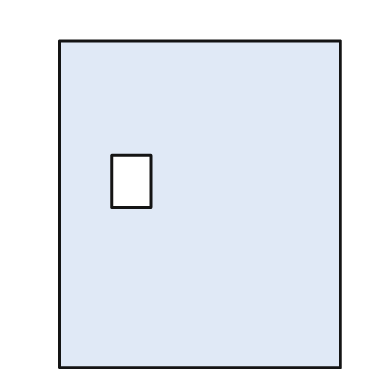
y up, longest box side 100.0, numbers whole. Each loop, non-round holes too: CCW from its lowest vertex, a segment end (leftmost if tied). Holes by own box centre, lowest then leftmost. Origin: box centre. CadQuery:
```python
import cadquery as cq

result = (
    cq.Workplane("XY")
    .moveTo(-43.0, -50.0)
    .lineTo(43.0, -50.0)
    .lineTo(43.0, 50.0)
    .lineTo(-43.0, 50.0)
    .close()
    .moveTo(-27.0, -1.0)
    .lineTo(-15.0, -1.0)
    .lineTo(-15.0, 15.0)
    .lineTo(-27.0, 15.0)
    .close()
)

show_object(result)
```